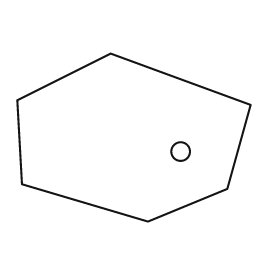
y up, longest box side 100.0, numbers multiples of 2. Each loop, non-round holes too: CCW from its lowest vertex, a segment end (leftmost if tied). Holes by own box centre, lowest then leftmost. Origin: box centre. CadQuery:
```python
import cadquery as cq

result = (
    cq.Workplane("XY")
    .moveTo(6.0, -36.0)
    .lineTo(40.0, -22.0)
    .lineTo(50.0, 14.0)
    .lineTo(-10.0, 36.0)
    .lineTo(-50.0, 16.0)
    .lineTo(-48.0, -20.0)
    .close()
    .moveTo(20.0, -6.0)
    .circle(4.0)
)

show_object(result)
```